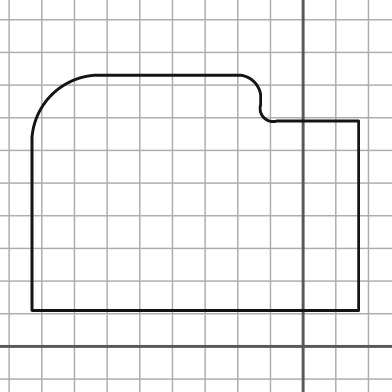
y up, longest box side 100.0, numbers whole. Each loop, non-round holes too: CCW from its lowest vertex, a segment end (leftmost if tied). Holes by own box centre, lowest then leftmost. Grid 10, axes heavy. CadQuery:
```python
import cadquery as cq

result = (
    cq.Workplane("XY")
    .moveTo(-83.0, 11.0)
    .lineTo(17.0, 11.0)
    .lineTo(17.0, 69.0)
    .lineTo(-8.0, 69.0)
    .threePointArc((-12.0, 70.0), (-13.0, 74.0))
    .lineTo(-13.0, 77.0)
    .threePointArc((-15.0, 81.0), (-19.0, 83.0))
    .lineTo(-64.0, 83.0)
    .threePointArc((-77.0, 77.0), (-83.0, 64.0))
    .close()
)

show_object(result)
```